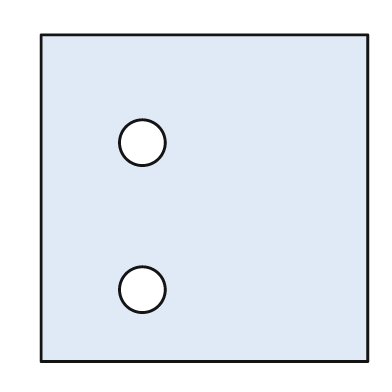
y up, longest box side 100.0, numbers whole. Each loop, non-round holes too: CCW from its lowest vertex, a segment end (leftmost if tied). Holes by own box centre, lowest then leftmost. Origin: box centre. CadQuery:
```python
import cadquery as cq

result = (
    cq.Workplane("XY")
    .moveTo(-50.0, -50.0)
    .lineTo(50.0, -50.0)
    .lineTo(50.0, 50.0)
    .lineTo(-50.0, 50.0)
    .close()
    .moveTo(-19.0, -28.0)
    .circle(7.0)
    .moveTo(-19.0, 17.0)
    .circle(7.0)
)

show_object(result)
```